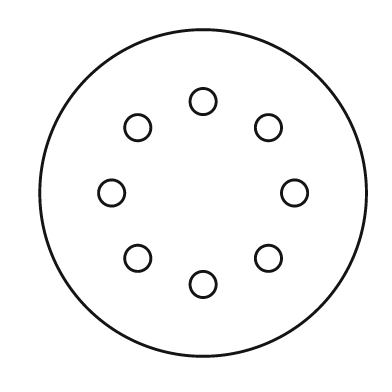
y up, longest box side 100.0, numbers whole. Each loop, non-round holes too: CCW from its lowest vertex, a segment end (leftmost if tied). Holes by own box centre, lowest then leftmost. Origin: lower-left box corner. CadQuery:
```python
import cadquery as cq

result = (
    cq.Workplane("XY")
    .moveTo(50.0, 50.0)
    .circle(50.0)
    .moveTo(50.0, 22.0)
    .circle(4.0)
    .moveTo(30.0, 30.0)
    .circle(4.0)
    .moveTo(70.0, 30.0)
    .circle(4.0)
    .moveTo(22.0, 50.0)
    .circle(4.0)
    .moveTo(78.0, 50.0)
    .circle(4.0)
    .moveTo(30.0, 70.0)
    .circle(4.0)
    .moveTo(70.0, 70.0)
    .circle(4.0)
    .moveTo(50.0, 78.0)
    .circle(4.0)
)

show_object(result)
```